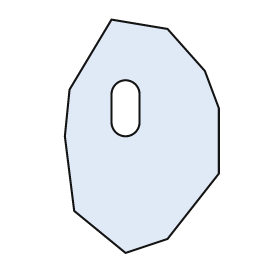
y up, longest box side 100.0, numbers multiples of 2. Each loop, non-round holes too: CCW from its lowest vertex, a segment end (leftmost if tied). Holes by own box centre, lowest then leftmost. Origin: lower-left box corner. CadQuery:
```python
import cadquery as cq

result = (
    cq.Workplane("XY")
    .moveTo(26.0, 0.0)
    .lineTo(44.0, 6.0)
    .lineTo(66.0, 34.0)
    .lineTo(66.0, 62.0)
    .lineTo(60.0, 78.0)
    .lineTo(44.0, 96.0)
    .lineTo(20.0, 100.0)
    .lineTo(2.0, 70.0)
    .lineTo(0.0, 50.0)
    .lineTo(4.0, 18.0)
    .close()
    .moveTo(20.0, 56.0)
    .threePointArc((26.0, 50.0), (32.0, 56.0))
    .lineTo(32.0, 68.0)
    .threePointArc((26.0, 74.0), (20.0, 68.0))
    .close()
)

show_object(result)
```